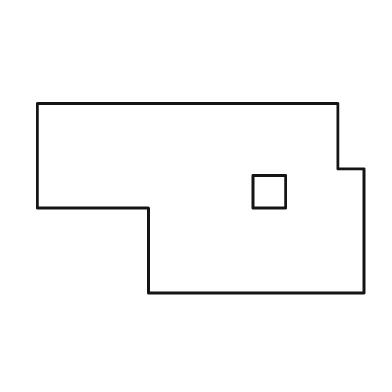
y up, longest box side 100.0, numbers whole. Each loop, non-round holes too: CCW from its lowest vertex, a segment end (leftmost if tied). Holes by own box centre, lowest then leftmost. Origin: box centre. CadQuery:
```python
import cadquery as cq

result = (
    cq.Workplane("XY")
    .moveTo(-16.0, -29.0)
    .lineTo(50.0, -29.0)
    .lineTo(50.0, 9.0)
    .lineTo(42.0, 9.0)
    .lineTo(42.0, 29.0)
    .lineTo(-50.0, 29.0)
    .lineTo(-50.0, -3.0)
    .lineTo(-16.0, -3.0)
    .close()
    .moveTo(16.0, -3.0)
    .lineTo(26.0, -3.0)
    .lineTo(26.0, 7.0)
    .lineTo(16.0, 7.0)
    .close()
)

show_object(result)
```